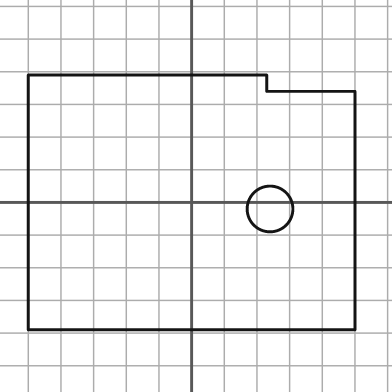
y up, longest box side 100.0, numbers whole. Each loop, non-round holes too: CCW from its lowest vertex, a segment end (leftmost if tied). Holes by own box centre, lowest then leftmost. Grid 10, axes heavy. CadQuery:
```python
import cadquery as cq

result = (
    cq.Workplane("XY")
    .moveTo(-50.0, -39.0)
    .lineTo(50.0, -39.0)
    .lineTo(50.0, 34.0)
    .lineTo(23.0, 34.0)
    .lineTo(23.0, 39.0)
    .lineTo(-50.0, 39.0)
    .close()
    .moveTo(24.0, -2.0)
    .circle(7.0)
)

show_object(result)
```